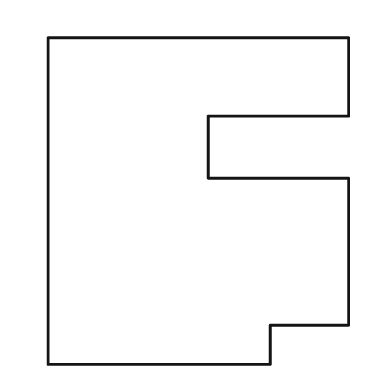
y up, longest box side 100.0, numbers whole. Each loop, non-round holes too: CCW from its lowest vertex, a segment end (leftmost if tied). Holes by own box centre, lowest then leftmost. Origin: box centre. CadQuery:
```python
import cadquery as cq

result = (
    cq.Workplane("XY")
    .moveTo(-46.0, -50.0)
    .lineTo(22.0, -50.0)
    .lineTo(22.0, -38.0)
    .lineTo(46.0, -38.0)
    .lineTo(46.0, 7.0)
    .lineTo(3.0, 7.0)
    .lineTo(3.0, 26.0)
    .lineTo(46.0, 26.0)
    .lineTo(46.0, 50.0)
    .lineTo(-46.0, 50.0)
    .close()
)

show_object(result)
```